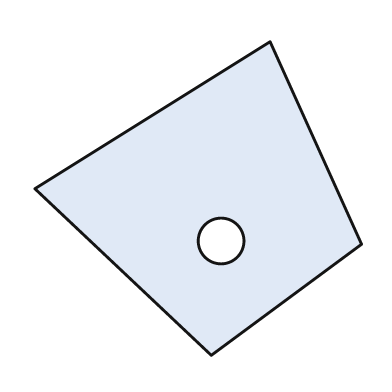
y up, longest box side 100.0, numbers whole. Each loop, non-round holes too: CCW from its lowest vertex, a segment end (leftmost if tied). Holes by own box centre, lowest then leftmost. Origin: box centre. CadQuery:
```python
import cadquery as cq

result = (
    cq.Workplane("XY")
    .moveTo(4.0, -48.0)
    .lineTo(50.0, -14.0)
    .lineTo(22.0, 48.0)
    .lineTo(-50.0, 3.0)
    .close()
    .moveTo(7.0, -13.0)
    .circle(7.0)
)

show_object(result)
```